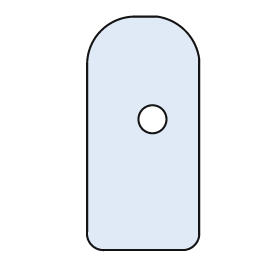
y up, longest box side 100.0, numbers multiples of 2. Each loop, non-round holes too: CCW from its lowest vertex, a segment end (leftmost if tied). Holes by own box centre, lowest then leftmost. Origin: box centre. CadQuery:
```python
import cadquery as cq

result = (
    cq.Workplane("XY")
    .moveTo(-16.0, -50.0)
    .lineTo(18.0, -50.0)
    .threePointArc((22.0, -48.0), (24.0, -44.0))
    .lineTo(24.0, 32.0)
    .threePointArc((18.0, 44.0), (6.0, 50.0))
    .lineTo(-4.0, 50.0)
    .threePointArc((-18.0, 44.0), (-24.0, 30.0))
    .lineTo(-24.0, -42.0)
    .threePointArc((-22.0, -48.0), (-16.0, -50.0))
    .close()
    .moveTo(4.0, 6.0)
    .circle(6.0)
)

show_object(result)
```